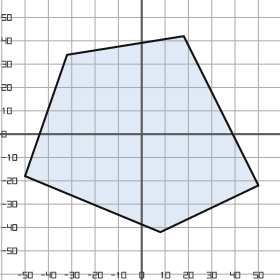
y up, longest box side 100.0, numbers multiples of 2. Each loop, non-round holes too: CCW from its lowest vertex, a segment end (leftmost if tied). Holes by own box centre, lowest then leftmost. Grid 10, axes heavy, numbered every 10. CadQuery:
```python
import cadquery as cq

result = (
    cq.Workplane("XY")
    .moveTo(8.0, -42.0)
    .lineTo(50.0, -22.0)
    .lineTo(18.0, 42.0)
    .lineTo(-32.0, 34.0)
    .lineTo(-50.0, -18.0)
    .close()
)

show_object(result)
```